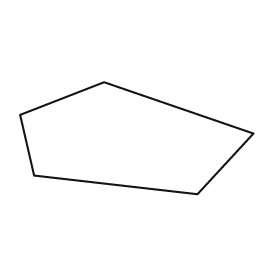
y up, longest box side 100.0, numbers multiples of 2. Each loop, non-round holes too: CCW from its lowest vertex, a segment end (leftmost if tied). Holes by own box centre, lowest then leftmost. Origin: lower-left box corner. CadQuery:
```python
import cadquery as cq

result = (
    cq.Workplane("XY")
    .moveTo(76.0, 0.0)
    .lineTo(100.0, 26.0)
    .lineTo(36.0, 48.0)
    .lineTo(0.0, 34.0)
    .lineTo(6.0, 8.0)
    .close()
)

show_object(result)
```